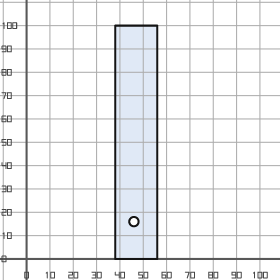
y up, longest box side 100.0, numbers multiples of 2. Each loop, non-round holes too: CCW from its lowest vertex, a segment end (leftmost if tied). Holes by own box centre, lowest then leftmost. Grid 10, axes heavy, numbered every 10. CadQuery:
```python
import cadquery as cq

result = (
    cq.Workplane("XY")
    .moveTo(38.0, 0.0)
    .lineTo(56.0, 0.0)
    .lineTo(56.0, 100.0)
    .lineTo(38.0, 100.0)
    .close()
    .moveTo(46.0, 16.0)
    .circle(2.0)
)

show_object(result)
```